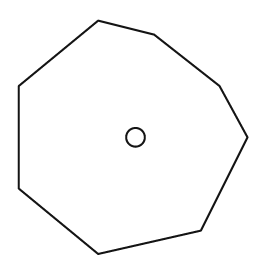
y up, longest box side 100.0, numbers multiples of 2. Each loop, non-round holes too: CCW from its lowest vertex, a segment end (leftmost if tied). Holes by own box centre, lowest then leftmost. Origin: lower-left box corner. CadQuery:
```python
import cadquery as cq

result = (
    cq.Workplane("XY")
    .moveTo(34.0, 0.0)
    .lineTo(78.0, 10.0)
    .lineTo(98.0, 50.0)
    .lineTo(86.0, 72.0)
    .lineTo(58.0, 94.0)
    .lineTo(34.0, 100.0)
    .lineTo(0.0, 72.0)
    .lineTo(0.0, 28.0)
    .close()
    .moveTo(50.0, 50.0)
    .circle(4.0)
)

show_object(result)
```